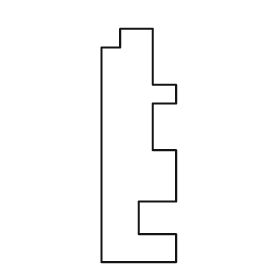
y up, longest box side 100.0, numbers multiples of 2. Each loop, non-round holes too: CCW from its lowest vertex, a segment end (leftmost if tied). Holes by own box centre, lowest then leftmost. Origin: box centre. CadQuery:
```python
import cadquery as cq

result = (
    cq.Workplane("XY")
    .moveTo(-16.0, -50.0)
    .lineTo(16.0, -50.0)
    .lineTo(16.0, -38.0)
    .lineTo(0.0, -38.0)
    .lineTo(0.0, -24.0)
    .lineTo(16.0, -24.0)
    .lineTo(16.0, -2.0)
    .lineTo(6.0, -2.0)
    .lineTo(6.0, 18.0)
    .lineTo(16.0, 18.0)
    .lineTo(16.0, 26.0)
    .lineTo(6.0, 26.0)
    .lineTo(6.0, 50.0)
    .lineTo(-8.0, 50.0)
    .lineTo(-8.0, 42.0)
    .lineTo(-16.0, 42.0)
    .close()
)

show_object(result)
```